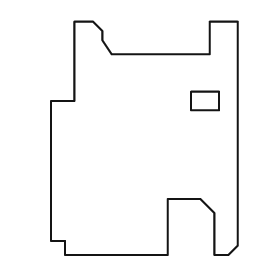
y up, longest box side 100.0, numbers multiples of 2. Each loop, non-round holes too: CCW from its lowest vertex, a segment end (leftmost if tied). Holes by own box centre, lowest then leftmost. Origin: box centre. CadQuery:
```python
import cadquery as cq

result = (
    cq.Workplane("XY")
    .moveTo(-34.0, -50.0)
    .lineTo(10.0, -50.0)
    .lineTo(10.0, -26.0)
    .lineTo(24.0, -26.0)
    .lineTo(30.0, -32.0)
    .lineTo(30.0, -50.0)
    .lineTo(36.0, -50.0)
    .lineTo(40.0, -46.0)
    .lineTo(40.0, 50.0)
    .lineTo(28.0, 50.0)
    .lineTo(28.0, 36.0)
    .lineTo(-14.0, 36.0)
    .lineTo(-18.0, 42.0)
    .lineTo(-18.0, 46.0)
    .lineTo(-22.0, 50.0)
    .lineTo(-30.0, 50.0)
    .lineTo(-30.0, 16.0)
    .lineTo(-40.0, 16.0)
    .lineTo(-40.0, -44.0)
    .lineTo(-34.0, -44.0)
    .close()
    .moveTo(20.0, 12.0)
    .lineTo(32.0, 12.0)
    .lineTo(32.0, 20.0)
    .lineTo(20.0, 20.0)
    .close()
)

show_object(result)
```